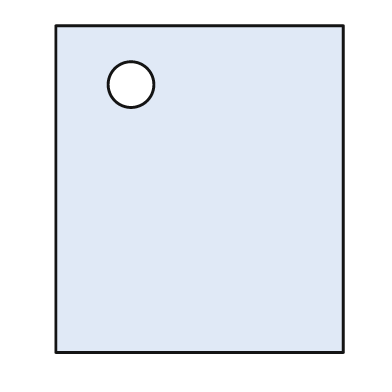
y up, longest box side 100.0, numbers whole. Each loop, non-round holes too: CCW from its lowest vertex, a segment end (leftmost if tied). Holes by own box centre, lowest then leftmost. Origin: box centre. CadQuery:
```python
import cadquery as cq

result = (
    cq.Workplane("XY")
    .moveTo(-44.0, -50.0)
    .lineTo(44.0, -50.0)
    .lineTo(44.0, 50.0)
    .lineTo(-44.0, 50.0)
    .close()
    .moveTo(-21.0, 32.0)
    .circle(7.0)
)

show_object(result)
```